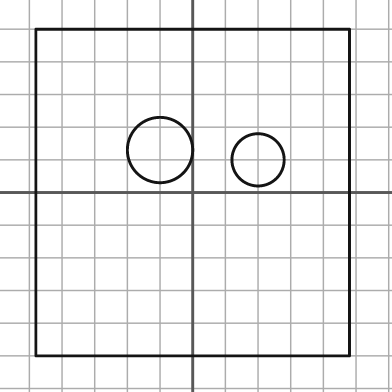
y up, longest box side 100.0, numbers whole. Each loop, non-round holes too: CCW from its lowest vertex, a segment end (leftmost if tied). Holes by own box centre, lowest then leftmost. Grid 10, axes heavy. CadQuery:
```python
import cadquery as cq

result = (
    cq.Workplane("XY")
    .moveTo(-48.0, -50.0)
    .lineTo(48.0, -50.0)
    .lineTo(48.0, 50.0)
    .lineTo(-48.0, 50.0)
    .close()
    .moveTo(20.0, 10.0)
    .circle(8.0)
    .moveTo(-10.0, 13.0)
    .circle(10.0)
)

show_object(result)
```